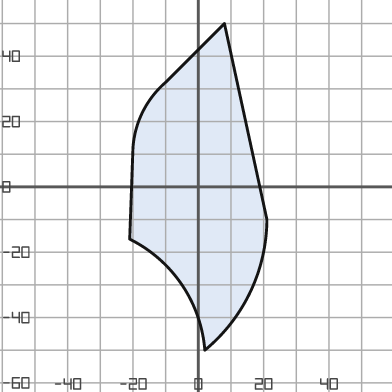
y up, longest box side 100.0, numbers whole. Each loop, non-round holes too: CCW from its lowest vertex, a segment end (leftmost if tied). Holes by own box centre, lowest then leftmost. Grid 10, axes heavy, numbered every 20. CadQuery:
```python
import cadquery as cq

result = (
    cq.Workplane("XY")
    .moveTo(2.0, -50.0)
    .threePointArc((16.0, -32.0), (21.0, -10.0))
    .lineTo(8.0, 50.0)
    .lineTo(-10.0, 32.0)
    .threePointArc((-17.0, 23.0), (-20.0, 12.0))
    .lineTo(-21.0, -16.0)
    .threePointArc((-5.0, -30.0), (2.0, -50.0))
    .close()
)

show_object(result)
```